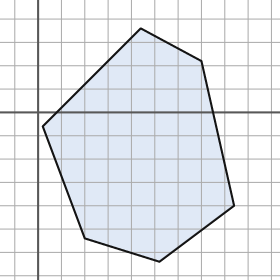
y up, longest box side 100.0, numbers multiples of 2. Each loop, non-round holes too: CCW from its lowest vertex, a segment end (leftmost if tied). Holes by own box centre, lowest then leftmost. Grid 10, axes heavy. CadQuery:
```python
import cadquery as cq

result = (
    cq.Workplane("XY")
    .moveTo(52.0, -64.0)
    .lineTo(84.0, -40.0)
    .lineTo(70.0, 22.0)
    .lineTo(44.0, 36.0)
    .lineTo(2.0, -6.0)
    .lineTo(20.0, -54.0)
    .close()
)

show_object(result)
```